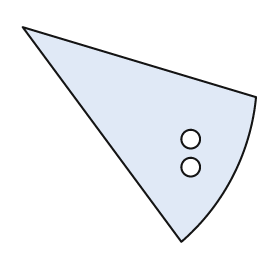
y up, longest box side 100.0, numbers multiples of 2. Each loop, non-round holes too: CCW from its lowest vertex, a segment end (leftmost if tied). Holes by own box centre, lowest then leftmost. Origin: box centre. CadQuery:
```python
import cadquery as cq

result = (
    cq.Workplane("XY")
    .moveTo(18.0, -46.0)
    .threePointArc((40.0, -18.0), (50.0, 16.0))
    .lineTo(-50.0, 46.0)
    .close()
    .moveTo(22.0, -14.0)
    .circle(4.0)
    .moveTo(22.0, -2.0)
    .circle(4.0)
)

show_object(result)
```